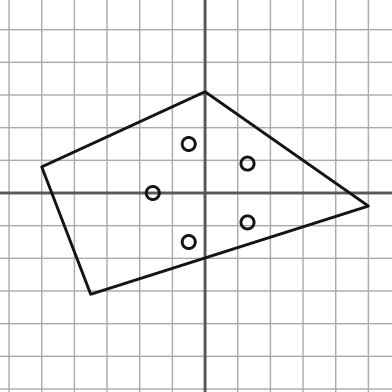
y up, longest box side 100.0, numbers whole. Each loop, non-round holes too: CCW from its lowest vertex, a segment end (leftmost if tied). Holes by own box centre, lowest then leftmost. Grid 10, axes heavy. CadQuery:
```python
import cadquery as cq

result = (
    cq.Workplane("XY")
    .moveTo(-35.0, -31.0)
    .lineTo(50.0, -4.0)
    .lineTo(0.0, 31.0)
    .lineTo(-50.0, 8.0)
    .close()
    .moveTo(-5.0, -15.0)
    .circle(2.0)
    .moveTo(13.0, -9.0)
    .circle(2.0)
    .moveTo(-16.0, 0.0)
    .circle(2.0)
    .moveTo(13.0, 9.0)
    .circle(2.0)
    .moveTo(-5.0, 15.0)
    .circle(2.0)
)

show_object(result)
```